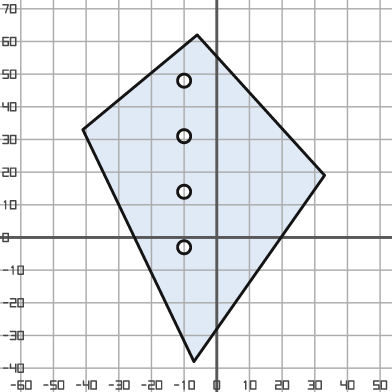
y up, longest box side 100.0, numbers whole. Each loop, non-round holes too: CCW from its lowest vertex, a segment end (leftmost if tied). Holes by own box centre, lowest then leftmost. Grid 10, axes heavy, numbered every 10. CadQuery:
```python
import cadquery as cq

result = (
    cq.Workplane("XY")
    .moveTo(-7.0, -38.0)
    .lineTo(33.0, 19.0)
    .lineTo(-6.0, 62.0)
    .lineTo(-41.0, 33.0)
    .close()
    .moveTo(-10.0, -3.0)
    .circle(2.0)
    .moveTo(-10.0, 14.0)
    .circle(2.0)
    .moveTo(-10.0, 31.0)
    .circle(2.0)
    .moveTo(-10.0, 48.0)
    .circle(2.0)
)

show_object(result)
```